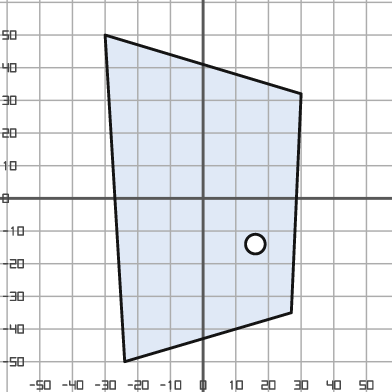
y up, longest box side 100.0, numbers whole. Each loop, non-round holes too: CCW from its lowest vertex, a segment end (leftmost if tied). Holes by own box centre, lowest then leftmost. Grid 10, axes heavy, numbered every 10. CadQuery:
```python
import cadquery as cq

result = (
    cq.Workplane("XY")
    .moveTo(-24.0, -50.0)
    .lineTo(27.0, -35.0)
    .lineTo(30.0, 32.0)
    .lineTo(-30.0, 50.0)
    .close()
    .moveTo(16.0, -14.0)
    .circle(3.0)
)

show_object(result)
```